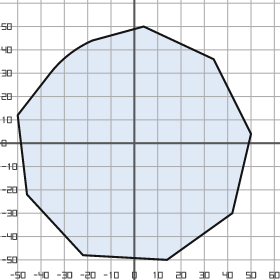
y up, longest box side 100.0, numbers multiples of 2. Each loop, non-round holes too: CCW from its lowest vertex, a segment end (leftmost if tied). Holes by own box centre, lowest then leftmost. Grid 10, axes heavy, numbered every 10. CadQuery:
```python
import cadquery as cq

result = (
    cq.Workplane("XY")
    .moveTo(14.0, -50.0)
    .lineTo(42.0, -30.0)
    .lineTo(50.0, 4.0)
    .lineTo(34.0, 36.0)
    .lineTo(4.0, 50.0)
    .lineTo(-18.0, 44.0)
    .threePointArc((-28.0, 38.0), (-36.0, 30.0))
    .lineTo(-50.0, 12.0)
    .lineTo(-46.0, -22.0)
    .lineTo(-22.0, -48.0)
    .close()
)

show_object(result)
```